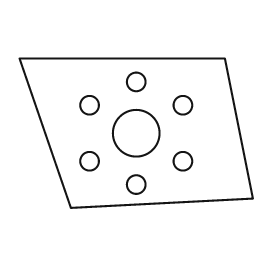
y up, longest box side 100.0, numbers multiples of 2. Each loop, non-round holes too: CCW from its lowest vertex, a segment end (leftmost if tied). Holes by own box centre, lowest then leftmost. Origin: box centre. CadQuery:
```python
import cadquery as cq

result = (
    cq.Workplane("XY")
    .moveTo(-28.0, -32.0)
    .lineTo(50.0, -28.0)
    .lineTo(38.0, 32.0)
    .lineTo(-50.0, 32.0)
    .close()
    .moveTo(0.0, -22.0)
    .circle(4.0)
    .moveTo(-20.0, -12.0)
    .circle(4.0)
    .moveTo(20.0, -12.0)
    .circle(4.0)
    .moveTo(0.0, 0.0)
    .circle(10.0)
    .moveTo(-20.0, 12.0)
    .circle(4.0)
    .moveTo(20.0, 12.0)
    .circle(4.0)
    .moveTo(0.0, 22.0)
    .circle(4.0)
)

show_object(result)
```